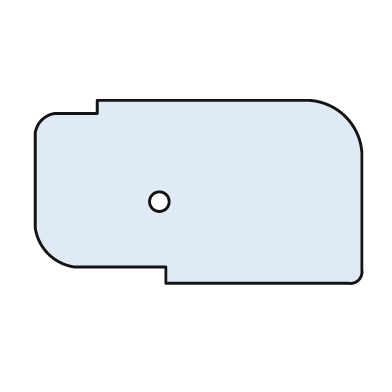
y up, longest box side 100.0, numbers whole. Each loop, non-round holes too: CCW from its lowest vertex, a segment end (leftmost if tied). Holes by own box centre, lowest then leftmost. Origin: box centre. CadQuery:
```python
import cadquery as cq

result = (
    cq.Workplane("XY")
    .moveTo(-10.0, -28.0)
    .lineTo(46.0, -28.0)
    .threePointArc((49.0, -27.0), (50.0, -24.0))
    .lineTo(50.0, 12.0)
    .threePointArc((45.0, 23.0), (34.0, 28.0))
    .lineTo(-31.0, 28.0)
    .lineTo(-31.0, 24.0)
    .lineTo(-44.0, 24.0)
    .threePointArc((-48.0, 22.0), (-50.0, 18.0))
    .lineTo(-50.0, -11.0)
    .threePointArc((-46.0, -19.0), (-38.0, -23.0))
    .lineTo(-10.0, -23.0)
    .close()
    .moveTo(-12.0, -3.0)
    .circle(3.0)
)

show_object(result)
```